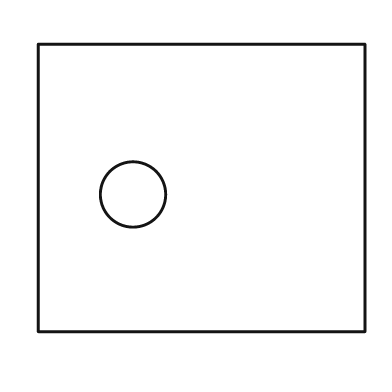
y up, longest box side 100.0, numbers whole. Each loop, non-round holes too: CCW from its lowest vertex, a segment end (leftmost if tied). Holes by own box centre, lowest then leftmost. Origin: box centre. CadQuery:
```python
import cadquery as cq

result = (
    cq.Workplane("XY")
    .moveTo(-50.0, -44.0)
    .lineTo(50.0, -44.0)
    .lineTo(50.0, 44.0)
    .lineTo(-50.0, 44.0)
    .close()
    .moveTo(-21.0, -2.0)
    .circle(10.0)
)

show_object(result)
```